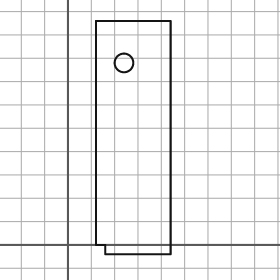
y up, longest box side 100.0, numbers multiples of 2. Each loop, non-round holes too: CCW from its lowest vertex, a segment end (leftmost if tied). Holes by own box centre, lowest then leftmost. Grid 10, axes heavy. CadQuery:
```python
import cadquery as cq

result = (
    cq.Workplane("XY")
    .moveTo(16.0, -4.0)
    .lineTo(44.0, -4.0)
    .lineTo(44.0, 96.0)
    .lineTo(12.0, 96.0)
    .lineTo(12.0, 0.0)
    .lineTo(16.0, 0.0)
    .close()
    .moveTo(24.0, 78.0)
    .circle(4.0)
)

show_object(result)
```